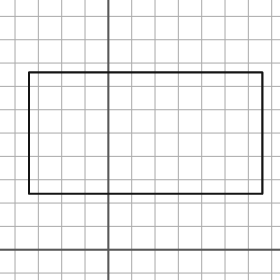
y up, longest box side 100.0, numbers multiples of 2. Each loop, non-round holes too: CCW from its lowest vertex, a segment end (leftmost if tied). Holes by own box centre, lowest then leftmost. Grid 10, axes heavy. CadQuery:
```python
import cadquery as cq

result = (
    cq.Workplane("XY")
    .moveTo(-34.0, 24.0)
    .lineTo(66.0, 24.0)
    .lineTo(66.0, 76.0)
    .lineTo(-34.0, 76.0)
    .close()
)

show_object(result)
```